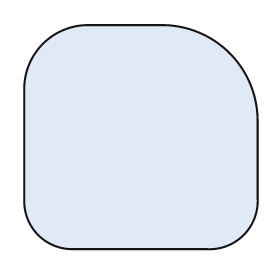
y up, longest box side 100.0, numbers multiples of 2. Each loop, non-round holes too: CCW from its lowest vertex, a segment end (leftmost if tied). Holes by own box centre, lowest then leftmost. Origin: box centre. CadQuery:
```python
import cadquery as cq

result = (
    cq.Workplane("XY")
    .moveTo(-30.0, -48.0)
    .lineTo(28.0, -48.0)
    .threePointArc((44.0, -42.0), (50.0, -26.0))
    .lineTo(50.0, 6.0)
    .threePointArc((38.0, 36.0), (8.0, 48.0))
    .lineTo(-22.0, 48.0)
    .threePointArc((-42.0, 40.0), (-50.0, 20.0))
    .lineTo(-50.0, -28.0)
    .threePointArc((-44.0, -42.0), (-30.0, -48.0))
    .close()
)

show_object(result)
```